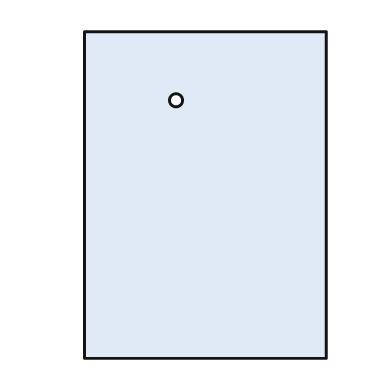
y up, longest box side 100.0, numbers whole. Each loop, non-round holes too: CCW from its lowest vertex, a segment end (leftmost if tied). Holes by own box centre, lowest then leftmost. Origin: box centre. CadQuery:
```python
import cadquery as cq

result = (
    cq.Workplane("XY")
    .moveTo(-37.0, -50.0)
    .lineTo(37.0, -50.0)
    .lineTo(37.0, 50.0)
    .lineTo(-37.0, 50.0)
    .close()
    .moveTo(-9.0, 29.0)
    .circle(2.0)
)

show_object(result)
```